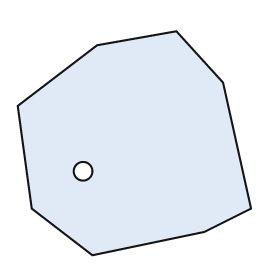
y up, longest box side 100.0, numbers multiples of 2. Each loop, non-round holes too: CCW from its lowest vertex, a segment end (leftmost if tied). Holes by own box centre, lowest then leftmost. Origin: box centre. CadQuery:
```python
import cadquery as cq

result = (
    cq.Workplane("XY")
    .moveTo(-18.0, -48.0)
    .lineTo(30.0, -38.0)
    .lineTo(50.0, -28.0)
    .lineTo(38.0, 26.0)
    .lineTo(18.0, 48.0)
    .lineTo(-16.0, 42.0)
    .lineTo(-50.0, 16.0)
    .lineTo(-44.0, -28.0)
    .close()
    .moveTo(-22.0, -12.0)
    .circle(4.0)
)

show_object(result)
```